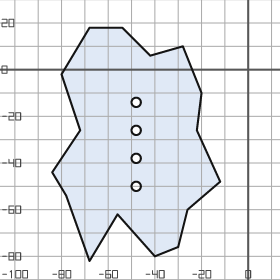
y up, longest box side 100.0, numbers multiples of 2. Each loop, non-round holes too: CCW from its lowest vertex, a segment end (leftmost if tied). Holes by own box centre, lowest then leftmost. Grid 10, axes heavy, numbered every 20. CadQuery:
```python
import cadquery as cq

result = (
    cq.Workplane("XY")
    .moveTo(-68.0, -82.0)
    .lineTo(-56.0, -62.0)
    .lineTo(-40.0, -80.0)
    .lineTo(-30.0, -76.0)
    .lineTo(-26.0, -60.0)
    .lineTo(-12.0, -48.0)
    .lineTo(-22.0, -26.0)
    .lineTo(-20.0, -10.0)
    .lineTo(-28.0, 10.0)
    .lineTo(-42.0, 6.0)
    .lineTo(-54.0, 18.0)
    .lineTo(-68.0, 18.0)
    .lineTo(-80.0, -2.0)
    .lineTo(-72.0, -26.0)
    .lineTo(-84.0, -44.0)
    .lineTo(-78.0, -54.0)
    .close()
    .moveTo(-48.0, -50.0)
    .circle(2.0)
    .moveTo(-48.0, -38.0)
    .circle(2.0)
    .moveTo(-48.0, -26.0)
    .circle(2.0)
    .moveTo(-48.0, -14.0)
    .circle(2.0)
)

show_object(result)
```